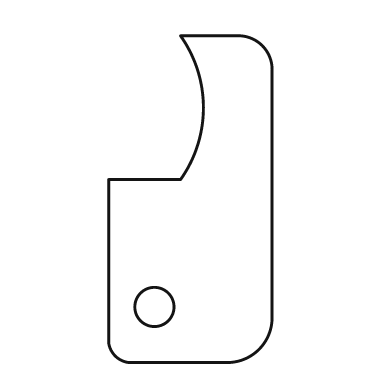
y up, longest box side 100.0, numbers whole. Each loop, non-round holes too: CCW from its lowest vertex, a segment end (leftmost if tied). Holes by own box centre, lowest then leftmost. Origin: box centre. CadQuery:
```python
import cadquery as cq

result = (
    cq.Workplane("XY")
    .moveTo(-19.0, -50.0)
    .lineTo(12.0, -50.0)
    .threePointArc((21.0, -46.0), (25.0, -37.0))
    .lineTo(25.0, 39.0)
    .threePointArc((22.0, 47.0), (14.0, 50.0))
    .lineTo(-3.0, 50.0)
    .threePointArc((4.0, 28.0), (-3.0, 6.0))
    .lineTo(-25.0, 6.0)
    .lineTo(-25.0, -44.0)
    .threePointArc((-23.0, -48.0), (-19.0, -50.0))
    .close()
    .moveTo(-11.0, -33.0)
    .circle(6.0)
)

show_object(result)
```